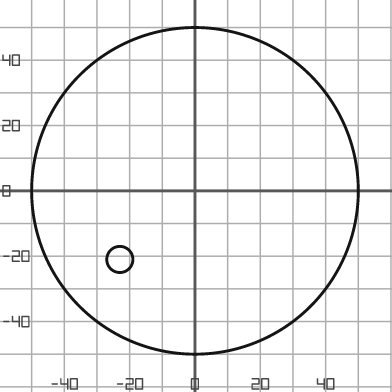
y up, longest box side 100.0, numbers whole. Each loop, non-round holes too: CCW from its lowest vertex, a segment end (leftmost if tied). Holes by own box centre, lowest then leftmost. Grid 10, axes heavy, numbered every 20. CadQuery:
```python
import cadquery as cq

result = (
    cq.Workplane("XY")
    .moveTo(0.0, 0.0)
    .circle(50.0)
    .moveTo(-23.0, -21.0)
    .circle(4.0)
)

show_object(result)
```